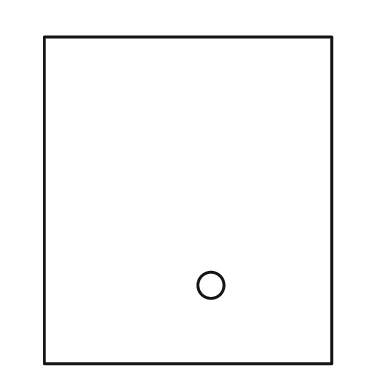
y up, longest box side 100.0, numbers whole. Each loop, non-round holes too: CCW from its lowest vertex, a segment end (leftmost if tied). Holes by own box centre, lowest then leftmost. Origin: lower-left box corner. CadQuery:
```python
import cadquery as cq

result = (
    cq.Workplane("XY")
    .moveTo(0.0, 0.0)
    .lineTo(88.0, 0.0)
    .lineTo(88.0, 100.0)
    .lineTo(0.0, 100.0)
    .close()
    .moveTo(51.0, 24.0)
    .circle(4.0)
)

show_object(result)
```